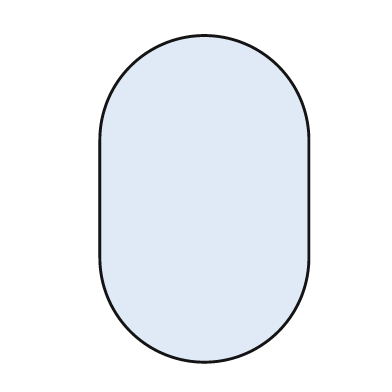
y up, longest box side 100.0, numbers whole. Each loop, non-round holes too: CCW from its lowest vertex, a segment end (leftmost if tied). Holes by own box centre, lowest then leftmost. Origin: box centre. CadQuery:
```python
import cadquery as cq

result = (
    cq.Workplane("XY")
    .moveTo(-32.0, -18.0)
    .threePointArc((0.0, -50.0), (32.0, -18.0))
    .lineTo(32.0, 18.0)
    .threePointArc((0.0, 50.0), (-32.0, 18.0))
    .close()
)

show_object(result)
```